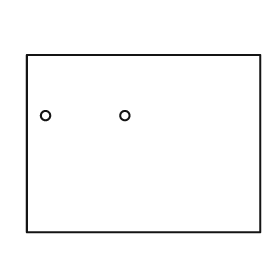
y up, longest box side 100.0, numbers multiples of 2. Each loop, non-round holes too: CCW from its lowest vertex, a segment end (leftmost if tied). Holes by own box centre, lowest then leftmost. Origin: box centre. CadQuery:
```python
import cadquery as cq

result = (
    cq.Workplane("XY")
    .moveTo(-50.0, -38.0)
    .lineTo(50.0, -38.0)
    .lineTo(50.0, 38.0)
    .lineTo(-50.0, 38.0)
    .close()
    .moveTo(-42.0, 12.0)
    .circle(2.0)
    .moveTo(-8.0, 12.0)
    .circle(2.0)
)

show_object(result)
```